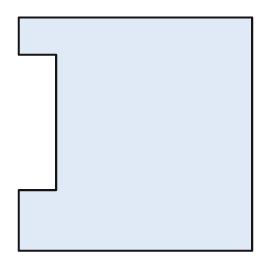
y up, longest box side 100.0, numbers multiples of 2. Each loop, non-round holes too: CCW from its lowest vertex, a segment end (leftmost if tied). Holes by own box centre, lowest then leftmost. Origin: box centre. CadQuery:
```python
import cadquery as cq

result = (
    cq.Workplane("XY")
    .moveTo(-50.0, -50.0)
    .lineTo(50.0, -50.0)
    .lineTo(50.0, 50.0)
    .lineTo(-50.0, 50.0)
    .lineTo(-50.0, 34.0)
    .lineTo(-34.0, 34.0)
    .lineTo(-34.0, -24.0)
    .lineTo(-50.0, -24.0)
    .close()
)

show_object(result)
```